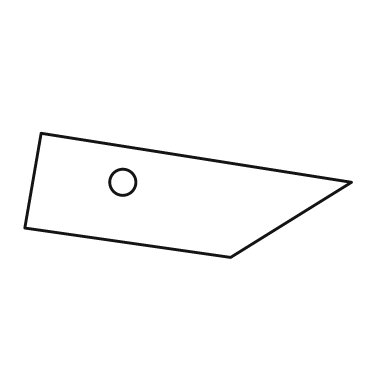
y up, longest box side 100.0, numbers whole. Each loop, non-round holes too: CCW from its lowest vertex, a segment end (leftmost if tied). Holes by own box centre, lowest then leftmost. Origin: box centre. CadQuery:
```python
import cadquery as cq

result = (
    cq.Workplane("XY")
    .moveTo(13.0, -19.0)
    .lineTo(50.0, 4.0)
    .lineTo(-45.0, 19.0)
    .lineTo(-50.0, -10.0)
    .close()
    .moveTo(-20.0, 4.0)
    .circle(4.0)
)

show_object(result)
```